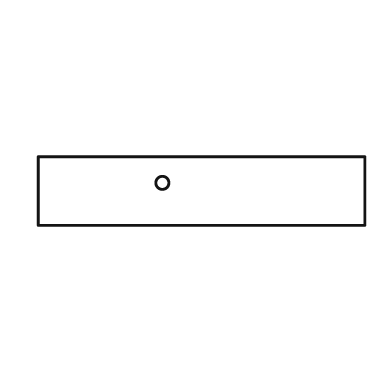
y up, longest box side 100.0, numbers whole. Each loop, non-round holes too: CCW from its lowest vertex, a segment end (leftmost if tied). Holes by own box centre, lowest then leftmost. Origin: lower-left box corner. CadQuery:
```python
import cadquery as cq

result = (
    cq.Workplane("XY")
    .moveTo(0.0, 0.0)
    .lineTo(100.0, 0.0)
    .lineTo(100.0, 21.0)
    .lineTo(0.0, 21.0)
    .close()
    .moveTo(38.0, 13.0)
    .circle(2.0)
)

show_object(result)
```